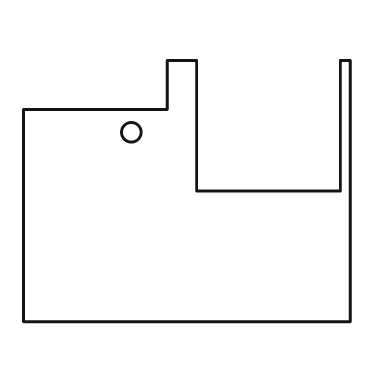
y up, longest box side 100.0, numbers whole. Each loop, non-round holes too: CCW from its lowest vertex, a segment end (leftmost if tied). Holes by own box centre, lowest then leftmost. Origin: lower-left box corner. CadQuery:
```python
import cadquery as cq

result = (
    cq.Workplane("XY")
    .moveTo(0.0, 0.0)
    .lineTo(100.0, 0.0)
    .lineTo(100.0, 80.0)
    .lineTo(97.0, 80.0)
    .lineTo(97.0, 40.0)
    .lineTo(53.0, 40.0)
    .lineTo(53.0, 80.0)
    .lineTo(44.0, 80.0)
    .lineTo(44.0, 65.0)
    .lineTo(0.0, 65.0)
    .close()
    .moveTo(33.0, 58.0)
    .circle(3.0)
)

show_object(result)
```